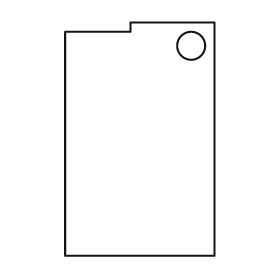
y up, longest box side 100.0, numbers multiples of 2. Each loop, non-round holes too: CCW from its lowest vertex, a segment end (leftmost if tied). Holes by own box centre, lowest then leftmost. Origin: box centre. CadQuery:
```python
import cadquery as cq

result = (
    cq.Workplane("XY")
    .moveTo(-32.0, -50.0)
    .lineTo(32.0, -50.0)
    .lineTo(32.0, 50.0)
    .lineTo(-4.0, 50.0)
    .lineTo(-4.0, 46.0)
    .lineTo(-32.0, 46.0)
    .close()
    .moveTo(22.0, 40.0)
    .circle(6.0)
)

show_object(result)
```